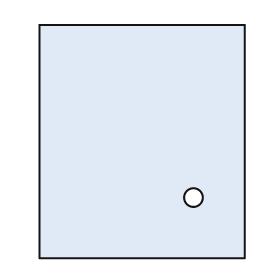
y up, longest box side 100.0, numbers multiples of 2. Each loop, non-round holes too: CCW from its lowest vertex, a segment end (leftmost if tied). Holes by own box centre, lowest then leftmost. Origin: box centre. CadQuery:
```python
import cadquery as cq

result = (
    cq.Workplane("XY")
    .moveTo(-44.0, -50.0)
    .lineTo(44.0, -50.0)
    .lineTo(44.0, 50.0)
    .lineTo(-44.0, 50.0)
    .close()
    .moveTo(22.0, -24.0)
    .circle(4.0)
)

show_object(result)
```